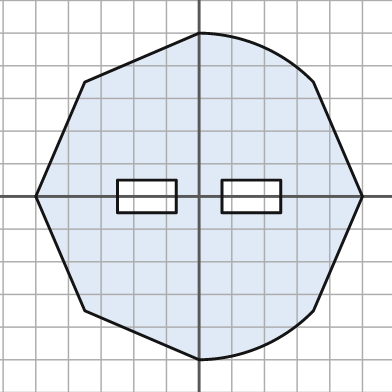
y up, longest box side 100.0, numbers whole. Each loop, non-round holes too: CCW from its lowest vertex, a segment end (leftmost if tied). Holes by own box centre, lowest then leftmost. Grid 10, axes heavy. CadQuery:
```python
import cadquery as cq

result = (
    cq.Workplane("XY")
    .moveTo(0.0, -50.0)
    .threePointArc((19.0, -46.0), (35.0, -35.0))
    .lineTo(50.0, 0.0)
    .lineTo(35.0, 35.0)
    .threePointArc((19.0, 46.0), (0.0, 50.0))
    .lineTo(-35.0, 35.0)
    .lineTo(-50.0, 0.0)
    .lineTo(-35.0, -35.0)
    .close()
    .moveTo(-25.0, -5.0)
    .lineTo(-7.0, -5.0)
    .lineTo(-7.0, 5.0)
    .lineTo(-25.0, 5.0)
    .close()
    .moveTo(7.0, -5.0)
    .lineTo(25.0, -5.0)
    .lineTo(25.0, 5.0)
    .lineTo(7.0, 5.0)
    .close()
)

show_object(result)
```